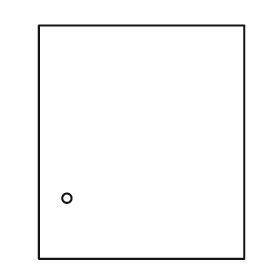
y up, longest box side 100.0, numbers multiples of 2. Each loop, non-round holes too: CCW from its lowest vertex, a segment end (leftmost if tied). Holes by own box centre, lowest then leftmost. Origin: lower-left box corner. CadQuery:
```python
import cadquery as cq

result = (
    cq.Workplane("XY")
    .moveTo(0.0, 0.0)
    .lineTo(88.0, 0.0)
    .lineTo(88.0, 100.0)
    .lineTo(0.0, 100.0)
    .close()
    .moveTo(12.0, 26.0)
    .circle(2.0)
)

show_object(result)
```